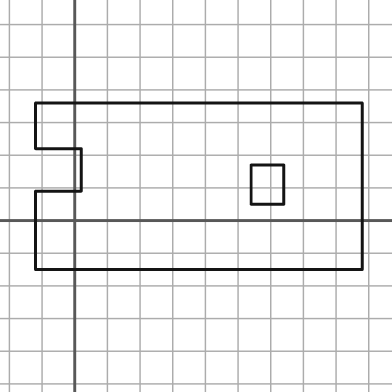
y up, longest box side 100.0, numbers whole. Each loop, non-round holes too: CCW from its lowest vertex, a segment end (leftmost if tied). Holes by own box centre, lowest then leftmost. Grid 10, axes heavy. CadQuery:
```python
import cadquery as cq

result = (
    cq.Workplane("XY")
    .moveTo(-12.0, -15.0)
    .lineTo(88.0, -15.0)
    .lineTo(88.0, 36.0)
    .lineTo(-12.0, 36.0)
    .lineTo(-12.0, 22.0)
    .lineTo(2.0, 22.0)
    .lineTo(2.0, 9.0)
    .lineTo(-12.0, 9.0)
    .close()
    .moveTo(54.0, 5.0)
    .lineTo(64.0, 5.0)
    .lineTo(64.0, 17.0)
    .lineTo(54.0, 17.0)
    .close()
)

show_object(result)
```